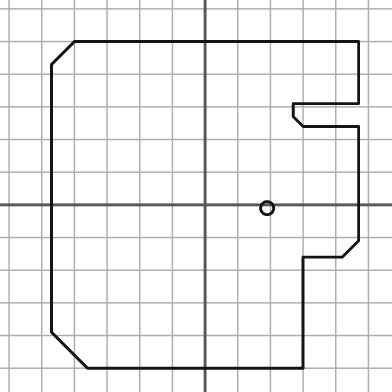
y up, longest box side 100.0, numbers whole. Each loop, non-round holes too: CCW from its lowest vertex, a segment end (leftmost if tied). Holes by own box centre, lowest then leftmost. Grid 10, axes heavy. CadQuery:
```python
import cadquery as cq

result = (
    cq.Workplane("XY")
    .moveTo(-36.0, -50.0)
    .lineTo(30.0, -50.0)
    .lineTo(30.0, -16.0)
    .lineTo(42.0, -16.0)
    .lineTo(47.0, -11.0)
    .lineTo(47.0, 24.0)
    .lineTo(30.0, 24.0)
    .lineTo(27.0, 27.0)
    .lineTo(27.0, 31.0)
    .lineTo(47.0, 31.0)
    .lineTo(47.0, 50.0)
    .lineTo(-40.0, 50.0)
    .lineTo(-47.0, 43.0)
    .lineTo(-47.0, -39.0)
    .close()
    .moveTo(19.0, -1.0)
    .circle(2.0)
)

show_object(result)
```